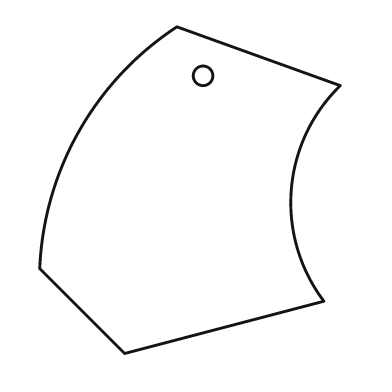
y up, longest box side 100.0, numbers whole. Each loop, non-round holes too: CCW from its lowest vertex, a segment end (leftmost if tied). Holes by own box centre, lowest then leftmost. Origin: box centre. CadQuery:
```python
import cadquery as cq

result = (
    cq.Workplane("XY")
    .moveTo(-20.0, -50.0)
    .lineTo(41.0, -34.0)
    .threePointArc((31.0, 0.0), (46.0, 32.0))
    .lineTo(-4.0, 50.0)
    .threePointArc((-34.0, 18.0), (-46.0, -24.0))
    .close()
    .moveTo(4.0, 35.0)
    .circle(3.0)
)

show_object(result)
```